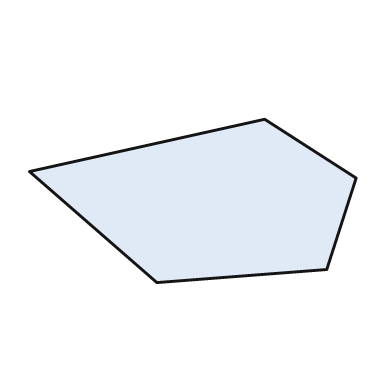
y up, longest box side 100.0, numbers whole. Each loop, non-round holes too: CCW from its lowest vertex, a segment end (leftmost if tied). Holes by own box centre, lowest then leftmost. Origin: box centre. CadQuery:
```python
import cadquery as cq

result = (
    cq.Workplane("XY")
    .moveTo(-11.0, -25.0)
    .lineTo(41.0, -21.0)
    .lineTo(50.0, 7.0)
    .lineTo(22.0, 25.0)
    .lineTo(-50.0, 9.0)
    .close()
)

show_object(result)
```